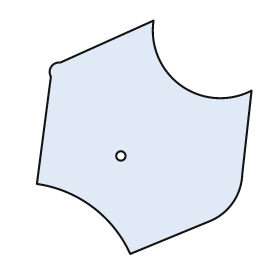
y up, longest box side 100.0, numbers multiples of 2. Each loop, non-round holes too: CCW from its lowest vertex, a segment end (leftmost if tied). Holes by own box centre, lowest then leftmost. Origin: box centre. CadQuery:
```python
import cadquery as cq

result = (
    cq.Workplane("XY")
    .moveTo(-6.0, -50.0)
    .lineTo(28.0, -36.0)
    .threePointArc((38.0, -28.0), (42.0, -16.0))
    .lineTo(46.0, 20.0)
    .threePointArc((16.0, 22.0), (4.0, 50.0))
    .lineTo(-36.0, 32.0)
    .threePointArc((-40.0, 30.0), (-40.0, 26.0))
    .lineTo(-46.0, -20.0)
    .threePointArc((-22.0, -30.0), (-6.0, -50.0))
    .close()
    .moveTo(-10.0, -8.0)
    .circle(2.0)
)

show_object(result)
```